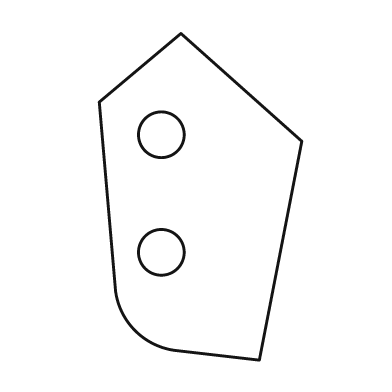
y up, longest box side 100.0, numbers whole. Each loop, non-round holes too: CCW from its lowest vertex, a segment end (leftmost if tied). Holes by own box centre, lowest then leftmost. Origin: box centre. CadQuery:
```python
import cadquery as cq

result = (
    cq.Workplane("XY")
    .moveTo(18.0, -50.0)
    .lineTo(31.0, 17.0)
    .lineTo(-6.0, 50.0)
    .lineTo(-31.0, 29.0)
    .lineTo(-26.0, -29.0)
    .threePointArc((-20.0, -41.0), (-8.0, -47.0))
    .close()
    .moveTo(-12.0, -17.0)
    .circle(7.0)
    .moveTo(-12.0, 19.0)
    .circle(7.0)
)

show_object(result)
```